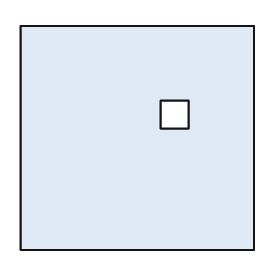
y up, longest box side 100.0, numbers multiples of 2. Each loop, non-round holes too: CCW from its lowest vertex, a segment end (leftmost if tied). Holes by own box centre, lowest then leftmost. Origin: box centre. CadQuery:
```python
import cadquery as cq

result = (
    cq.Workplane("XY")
    .moveTo(-50.0, -48.0)
    .lineTo(50.0, -48.0)
    .lineTo(50.0, 48.0)
    .lineTo(-50.0, 48.0)
    .close()
    .moveTo(10.0, 4.0)
    .lineTo(22.0, 4.0)
    .lineTo(22.0, 16.0)
    .lineTo(10.0, 16.0)
    .close()
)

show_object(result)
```